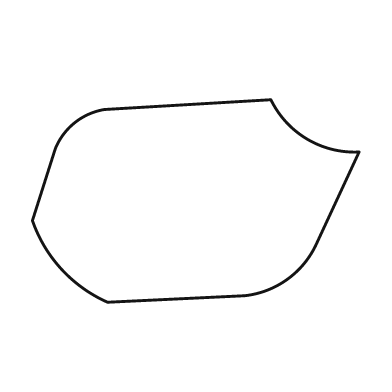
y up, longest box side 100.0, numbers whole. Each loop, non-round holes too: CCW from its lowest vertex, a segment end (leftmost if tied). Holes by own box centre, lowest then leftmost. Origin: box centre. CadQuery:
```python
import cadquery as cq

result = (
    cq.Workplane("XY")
    .moveTo(-27.0, -31.0)
    .lineTo(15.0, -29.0)
    .threePointArc((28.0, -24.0), (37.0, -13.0))
    .lineTo(50.0, 15.0)
    .threePointArc((34.0, 19.0), (23.0, 31.0))
    .lineTo(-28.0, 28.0)
    .threePointArc((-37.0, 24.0), (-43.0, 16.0))
    .lineTo(-50.0, -6.0)
    .threePointArc((-41.0, -21.0), (-27.0, -31.0))
    .close()
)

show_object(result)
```